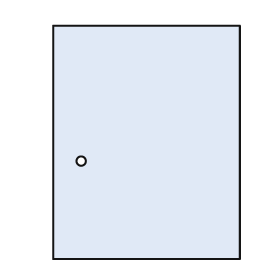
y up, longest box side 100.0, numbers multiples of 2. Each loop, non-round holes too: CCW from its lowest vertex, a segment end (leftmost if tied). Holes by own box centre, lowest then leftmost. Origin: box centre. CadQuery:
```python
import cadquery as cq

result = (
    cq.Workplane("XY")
    .moveTo(-40.0, -50.0)
    .lineTo(40.0, -50.0)
    .lineTo(40.0, 50.0)
    .lineTo(-40.0, 50.0)
    .close()
    .moveTo(-28.0, -8.0)
    .circle(2.0)
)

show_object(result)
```